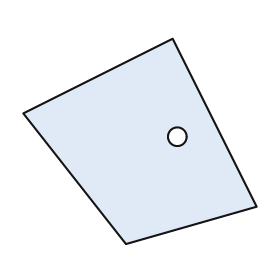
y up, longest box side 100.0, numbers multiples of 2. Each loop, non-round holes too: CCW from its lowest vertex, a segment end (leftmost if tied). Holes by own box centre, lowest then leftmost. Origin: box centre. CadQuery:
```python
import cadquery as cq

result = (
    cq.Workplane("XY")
    .moveTo(-6.0, -44.0)
    .lineTo(50.0, -28.0)
    .lineTo(14.0, 44.0)
    .lineTo(-50.0, 12.0)
    .close()
    .moveTo(16.0, 2.0)
    .circle(4.0)
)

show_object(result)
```